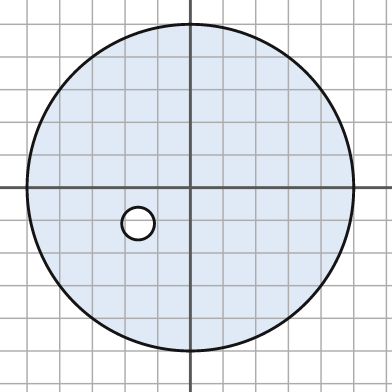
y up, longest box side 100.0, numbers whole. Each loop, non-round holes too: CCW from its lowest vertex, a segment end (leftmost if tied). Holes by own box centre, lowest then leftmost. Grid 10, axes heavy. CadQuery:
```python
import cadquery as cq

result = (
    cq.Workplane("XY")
    .moveTo(0.0, 0.0)
    .circle(50.0)
    .moveTo(-16.0, -11.0)
    .circle(5.0)
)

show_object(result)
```